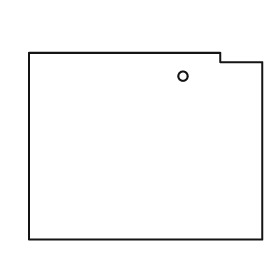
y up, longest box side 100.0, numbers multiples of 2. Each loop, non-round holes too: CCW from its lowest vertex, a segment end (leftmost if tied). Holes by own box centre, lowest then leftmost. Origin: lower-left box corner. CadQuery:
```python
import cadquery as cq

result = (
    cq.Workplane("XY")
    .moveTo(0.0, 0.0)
    .lineTo(100.0, 0.0)
    .lineTo(100.0, 76.0)
    .lineTo(82.0, 76.0)
    .lineTo(82.0, 80.0)
    .lineTo(0.0, 80.0)
    .close()
    .moveTo(66.0, 70.0)
    .circle(2.0)
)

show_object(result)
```